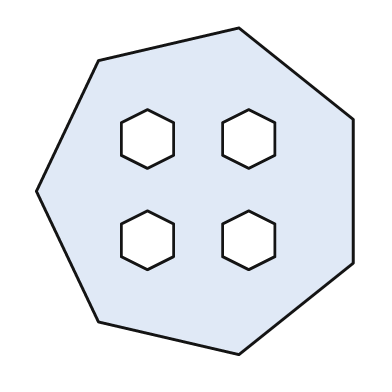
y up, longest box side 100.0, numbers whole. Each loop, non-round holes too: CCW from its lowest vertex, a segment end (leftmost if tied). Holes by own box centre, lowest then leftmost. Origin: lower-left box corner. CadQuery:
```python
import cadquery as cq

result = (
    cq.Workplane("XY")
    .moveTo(62.0, 0.0)
    .lineTo(97.0, 28.0)
    .lineTo(97.0, 72.0)
    .lineTo(62.0, 100.0)
    .lineTo(19.0, 90.0)
    .lineTo(0.0, 50.0)
    .lineTo(19.0, 10.0)
    .close()
    .moveTo(34.0, 26.0)
    .lineTo(42.0, 30.0)
    .lineTo(42.0, 40.0)
    .lineTo(34.0, 44.0)
    .lineTo(26.0, 40.0)
    .lineTo(26.0, 30.0)
    .close()
    .moveTo(65.0, 26.0)
    .lineTo(73.0, 30.0)
    .lineTo(73.0, 40.0)
    .lineTo(65.0, 44.0)
    .lineTo(57.0, 40.0)
    .lineTo(57.0, 30.0)
    .close()
    .moveTo(34.0, 57.0)
    .lineTo(42.0, 61.0)
    .lineTo(42.0, 71.0)
    .lineTo(34.0, 75.0)
    .lineTo(26.0, 71.0)
    .lineTo(26.0, 61.0)
    .close()
    .moveTo(65.0, 57.0)
    .lineTo(73.0, 61.0)
    .lineTo(73.0, 71.0)
    .lineTo(65.0, 75.0)
    .lineTo(57.0, 71.0)
    .lineTo(57.0, 61.0)
    .close()
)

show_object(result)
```